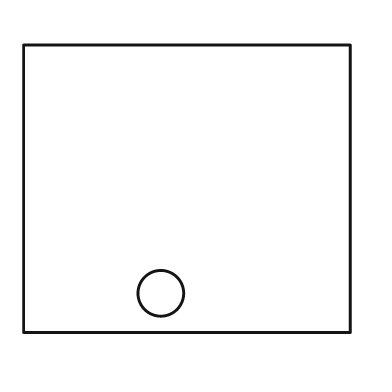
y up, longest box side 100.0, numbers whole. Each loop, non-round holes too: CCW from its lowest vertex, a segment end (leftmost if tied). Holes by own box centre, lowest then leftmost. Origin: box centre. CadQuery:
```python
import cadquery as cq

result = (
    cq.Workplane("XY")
    .moveTo(-50.0, -44.0)
    .lineTo(50.0, -44.0)
    .lineTo(50.0, 44.0)
    .lineTo(-50.0, 44.0)
    .close()
    .moveTo(-8.0, -32.0)
    .circle(7.0)
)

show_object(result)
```